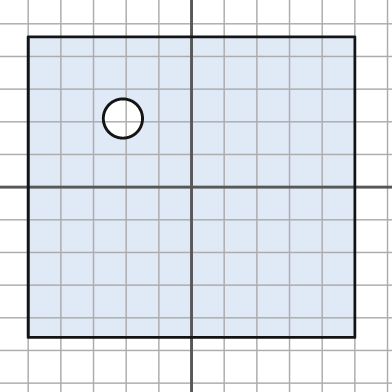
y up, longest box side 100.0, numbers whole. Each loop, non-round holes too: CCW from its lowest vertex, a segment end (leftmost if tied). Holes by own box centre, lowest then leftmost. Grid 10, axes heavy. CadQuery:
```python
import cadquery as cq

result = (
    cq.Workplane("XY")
    .moveTo(-50.0, -46.0)
    .lineTo(50.0, -46.0)
    .lineTo(50.0, 46.0)
    .lineTo(-50.0, 46.0)
    .close()
    .moveTo(-21.0, 21.0)
    .circle(6.0)
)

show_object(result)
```